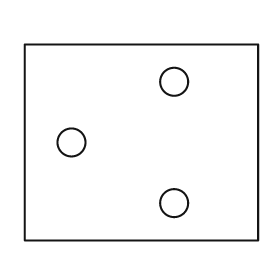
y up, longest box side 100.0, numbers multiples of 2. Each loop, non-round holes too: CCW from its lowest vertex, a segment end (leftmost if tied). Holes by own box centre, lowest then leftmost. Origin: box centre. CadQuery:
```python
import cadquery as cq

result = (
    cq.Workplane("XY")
    .moveTo(-50.0, -42.0)
    .lineTo(50.0, -42.0)
    .lineTo(50.0, 42.0)
    .lineTo(-50.0, 42.0)
    .close()
    .moveTo(14.0, -26.0)
    .circle(6.0)
    .moveTo(-30.0, 0.0)
    .circle(6.0)
    .moveTo(14.0, 26.0)
    .circle(6.0)
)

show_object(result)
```